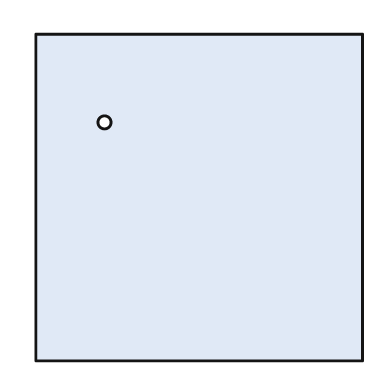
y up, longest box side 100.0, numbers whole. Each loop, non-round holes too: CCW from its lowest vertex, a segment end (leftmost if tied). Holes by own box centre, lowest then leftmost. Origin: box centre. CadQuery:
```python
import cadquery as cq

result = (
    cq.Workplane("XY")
    .moveTo(-50.0, -50.0)
    .lineTo(50.0, -50.0)
    .lineTo(50.0, 50.0)
    .lineTo(-50.0, 50.0)
    .close()
    .moveTo(-29.0, 23.0)
    .circle(2.0)
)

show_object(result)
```